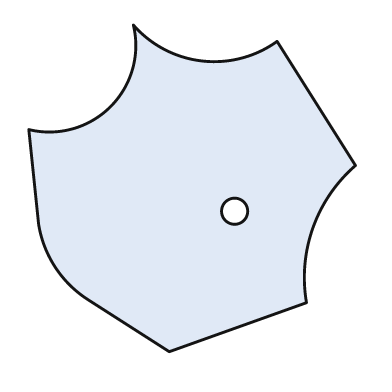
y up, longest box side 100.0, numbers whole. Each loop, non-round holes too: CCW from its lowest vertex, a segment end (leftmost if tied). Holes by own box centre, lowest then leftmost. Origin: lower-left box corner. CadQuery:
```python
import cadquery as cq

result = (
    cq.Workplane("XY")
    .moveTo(43.0, 0.0)
    .lineTo(85.0, 15.0)
    .threePointArc((87.0, 38.0), (100.0, 57.0))
    .lineTo(76.0, 95.0)
    .threePointArc((53.0, 89.0), (32.0, 100.0))
    .threePointArc((25.0, 75.0), (0.0, 68.0))
    .lineTo(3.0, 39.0)
    .threePointArc((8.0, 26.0), (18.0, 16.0))
    .close()
    .moveTo(63.0, 43.0)
    .circle(4.0)
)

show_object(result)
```